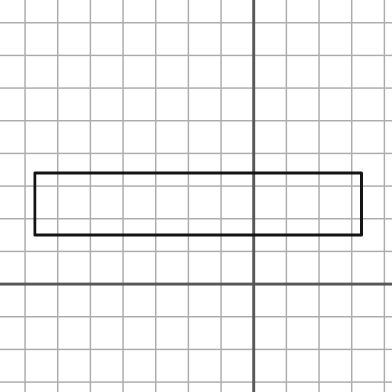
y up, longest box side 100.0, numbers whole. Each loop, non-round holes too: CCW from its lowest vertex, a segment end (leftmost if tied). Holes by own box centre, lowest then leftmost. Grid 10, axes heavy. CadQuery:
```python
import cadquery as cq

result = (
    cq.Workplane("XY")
    .moveTo(-67.0, 15.0)
    .lineTo(33.0, 15.0)
    .lineTo(33.0, 34.0)
    .lineTo(-67.0, 34.0)
    .close()
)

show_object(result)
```